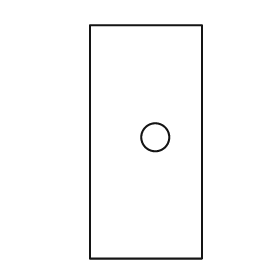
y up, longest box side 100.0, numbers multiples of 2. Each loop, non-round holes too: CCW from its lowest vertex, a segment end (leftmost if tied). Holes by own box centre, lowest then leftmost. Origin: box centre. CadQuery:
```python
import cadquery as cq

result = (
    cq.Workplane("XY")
    .moveTo(-24.0, -50.0)
    .lineTo(24.0, -50.0)
    .lineTo(24.0, 50.0)
    .lineTo(-24.0, 50.0)
    .close()
    .moveTo(4.0, 2.0)
    .circle(6.0)
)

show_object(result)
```